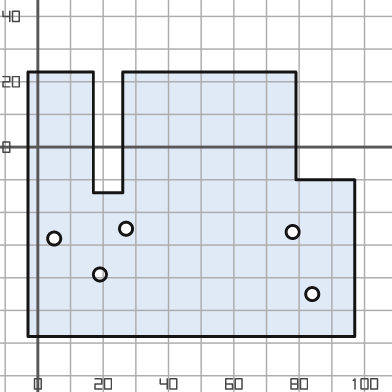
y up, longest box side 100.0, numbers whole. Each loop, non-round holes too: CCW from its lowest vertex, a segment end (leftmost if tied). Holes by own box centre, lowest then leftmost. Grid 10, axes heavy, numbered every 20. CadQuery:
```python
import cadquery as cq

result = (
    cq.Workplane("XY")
    .moveTo(-3.0, -58.0)
    .lineTo(97.0, -58.0)
    .lineTo(97.0, -10.0)
    .lineTo(79.0, -10.0)
    .lineTo(79.0, 23.0)
    .lineTo(26.0, 23.0)
    .lineTo(26.0, -14.0)
    .lineTo(17.0, -14.0)
    .lineTo(17.0, 23.0)
    .lineTo(-3.0, 23.0)
    .close()
    .moveTo(84.0, -45.0)
    .circle(2.0)
    .moveTo(19.0, -39.0)
    .circle(2.0)
    .moveTo(5.0, -28.0)
    .circle(2.0)
    .moveTo(78.0, -26.0)
    .circle(2.0)
    .moveTo(27.0, -25.0)
    .circle(2.0)
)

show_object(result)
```